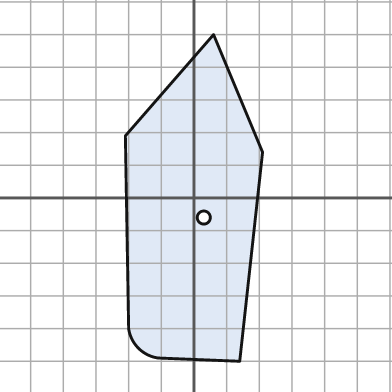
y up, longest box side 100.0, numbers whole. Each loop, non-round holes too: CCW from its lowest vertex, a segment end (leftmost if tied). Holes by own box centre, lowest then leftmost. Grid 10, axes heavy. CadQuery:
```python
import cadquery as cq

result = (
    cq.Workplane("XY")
    .moveTo(14.0, -50.0)
    .lineTo(21.0, 14.0)
    .lineTo(6.0, 50.0)
    .lineTo(-21.0, 19.0)
    .lineTo(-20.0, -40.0)
    .threePointArc((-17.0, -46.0), (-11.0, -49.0))
    .close()
    .moveTo(3.0, -6.0)
    .circle(2.0)
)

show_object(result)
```